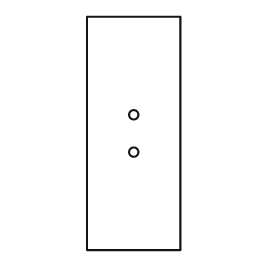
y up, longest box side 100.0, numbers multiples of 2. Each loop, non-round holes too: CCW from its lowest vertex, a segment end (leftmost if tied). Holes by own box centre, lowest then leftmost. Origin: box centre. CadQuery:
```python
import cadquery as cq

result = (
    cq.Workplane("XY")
    .moveTo(-20.0, -50.0)
    .lineTo(20.0, -50.0)
    .lineTo(20.0, 50.0)
    .lineTo(-20.0, 50.0)
    .close()
    .moveTo(0.0, -8.0)
    .circle(2.0)
    .moveTo(0.0, 8.0)
    .circle(2.0)
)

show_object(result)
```